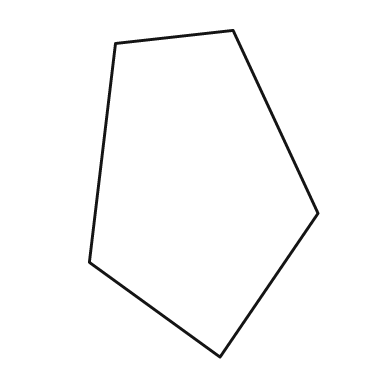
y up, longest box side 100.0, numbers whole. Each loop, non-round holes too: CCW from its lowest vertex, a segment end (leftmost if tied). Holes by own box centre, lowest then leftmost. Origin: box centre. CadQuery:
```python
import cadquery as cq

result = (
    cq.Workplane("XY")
    .moveTo(5.0, -50.0)
    .lineTo(35.0, -6.0)
    .lineTo(9.0, 50.0)
    .lineTo(-27.0, 46.0)
    .lineTo(-35.0, -21.0)
    .close()
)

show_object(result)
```